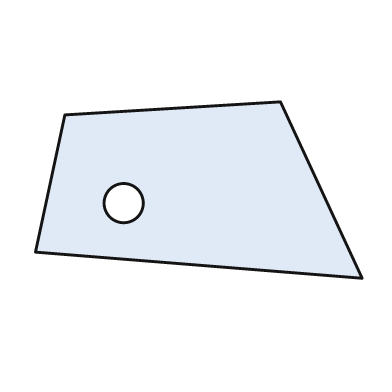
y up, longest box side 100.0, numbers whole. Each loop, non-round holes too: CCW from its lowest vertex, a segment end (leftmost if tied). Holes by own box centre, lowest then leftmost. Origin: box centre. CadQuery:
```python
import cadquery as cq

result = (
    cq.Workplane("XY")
    .moveTo(50.0, -27.0)
    .lineTo(25.0, 27.0)
    .lineTo(-41.0, 23.0)
    .lineTo(-50.0, -19.0)
    .close()
    .moveTo(-23.0, -4.0)
    .circle(6.0)
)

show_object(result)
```